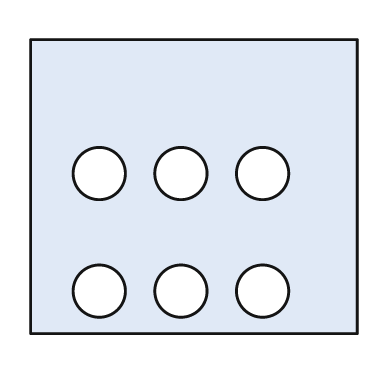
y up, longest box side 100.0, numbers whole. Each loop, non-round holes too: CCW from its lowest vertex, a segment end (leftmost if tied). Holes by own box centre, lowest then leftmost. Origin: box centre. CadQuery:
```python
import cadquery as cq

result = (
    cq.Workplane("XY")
    .moveTo(-50.0, -45.0)
    .lineTo(50.0, -45.0)
    .lineTo(50.0, 45.0)
    .lineTo(-50.0, 45.0)
    .close()
    .moveTo(-29.0, -32.0)
    .circle(8.0)
    .moveTo(-4.0, -32.0)
    .circle(8.0)
    .moveTo(21.0, -32.0)
    .circle(8.0)
    .moveTo(-29.0, 4.0)
    .circle(8.0)
    .moveTo(-4.0, 4.0)
    .circle(8.0)
    .moveTo(21.0, 4.0)
    .circle(8.0)
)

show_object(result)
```